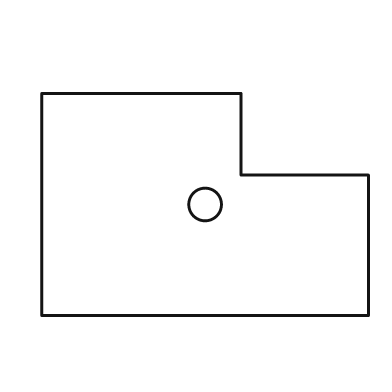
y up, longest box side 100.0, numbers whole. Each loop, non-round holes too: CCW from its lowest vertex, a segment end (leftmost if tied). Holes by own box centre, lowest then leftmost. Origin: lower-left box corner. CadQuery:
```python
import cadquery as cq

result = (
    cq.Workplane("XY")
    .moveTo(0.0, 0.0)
    .lineTo(100.0, 0.0)
    .lineTo(100.0, 43.0)
    .lineTo(61.0, 43.0)
    .lineTo(61.0, 68.0)
    .lineTo(0.0, 68.0)
    .close()
    .moveTo(50.0, 34.0)
    .circle(5.0)
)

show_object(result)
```